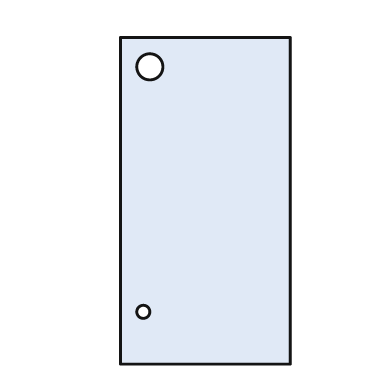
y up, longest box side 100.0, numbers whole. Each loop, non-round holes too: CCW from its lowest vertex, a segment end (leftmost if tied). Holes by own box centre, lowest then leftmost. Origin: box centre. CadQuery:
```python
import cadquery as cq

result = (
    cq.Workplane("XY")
    .moveTo(-26.0, -50.0)
    .lineTo(26.0, -50.0)
    .lineTo(26.0, 50.0)
    .lineTo(-26.0, 50.0)
    .close()
    .moveTo(-19.0, -34.0)
    .circle(2.0)
    .moveTo(-17.0, 41.0)
    .circle(4.0)
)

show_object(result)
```